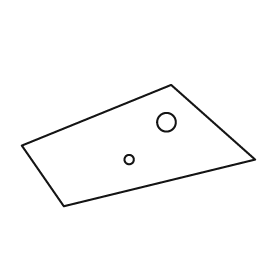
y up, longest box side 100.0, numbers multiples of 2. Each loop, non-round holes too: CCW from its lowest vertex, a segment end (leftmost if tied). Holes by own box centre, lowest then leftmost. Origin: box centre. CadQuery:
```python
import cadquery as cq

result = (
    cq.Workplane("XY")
    .moveTo(-32.0, -26.0)
    .lineTo(50.0, -6.0)
    .lineTo(14.0, 26.0)
    .lineTo(-50.0, 0.0)
    .close()
    .moveTo(-4.0, -6.0)
    .circle(2.0)
    .moveTo(12.0, 10.0)
    .circle(4.0)
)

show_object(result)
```